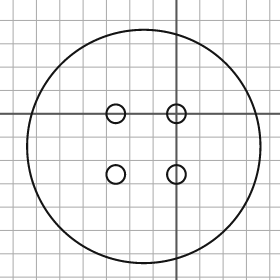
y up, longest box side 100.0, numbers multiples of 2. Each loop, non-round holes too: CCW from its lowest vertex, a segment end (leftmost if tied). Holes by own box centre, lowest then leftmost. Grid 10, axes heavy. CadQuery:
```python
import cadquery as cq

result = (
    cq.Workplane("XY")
    .moveTo(-14.0, -14.0)
    .circle(50.0)
    .moveTo(-26.0, -26.0)
    .circle(4.0)
    .moveTo(0.0, -26.0)
    .circle(4.0)
    .moveTo(-26.0, 0.0)
    .circle(4.0)
    .moveTo(0.0, 0.0)
    .circle(4.0)
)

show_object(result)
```